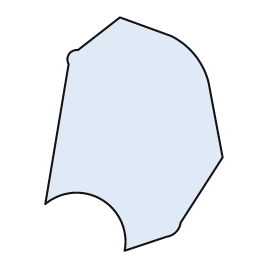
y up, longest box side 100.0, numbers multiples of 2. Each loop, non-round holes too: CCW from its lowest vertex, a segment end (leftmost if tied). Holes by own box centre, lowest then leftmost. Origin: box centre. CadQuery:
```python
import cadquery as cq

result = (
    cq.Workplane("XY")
    .moveTo(-4.0, -50.0)
    .lineTo(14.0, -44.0)
    .threePointArc((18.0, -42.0), (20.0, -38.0))
    .lineTo(38.0, -10.0)
    .lineTo(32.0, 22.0)
    .threePointArc((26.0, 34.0), (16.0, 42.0))
    .lineTo(-6.0, 50.0)
    .lineTo(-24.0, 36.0)
    .threePointArc((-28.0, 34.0), (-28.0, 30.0))
    .lineTo(-38.0, -30.0)
    .threePointArc((-14.0, -28.0), (-4.0, -50.0))
    .close()
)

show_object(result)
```